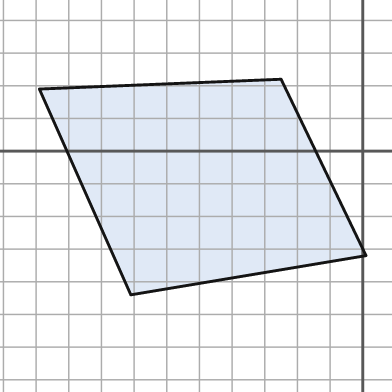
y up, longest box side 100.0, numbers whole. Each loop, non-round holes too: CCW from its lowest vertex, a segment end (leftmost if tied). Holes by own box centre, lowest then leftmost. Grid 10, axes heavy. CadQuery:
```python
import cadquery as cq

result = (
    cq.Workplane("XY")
    .moveTo(-71.0, -44.0)
    .lineTo(1.0, -32.0)
    .lineTo(-25.0, 22.0)
    .lineTo(-99.0, 19.0)
    .close()
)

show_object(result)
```